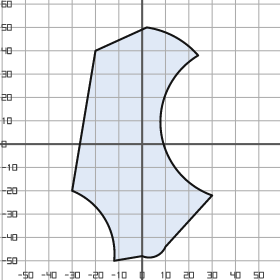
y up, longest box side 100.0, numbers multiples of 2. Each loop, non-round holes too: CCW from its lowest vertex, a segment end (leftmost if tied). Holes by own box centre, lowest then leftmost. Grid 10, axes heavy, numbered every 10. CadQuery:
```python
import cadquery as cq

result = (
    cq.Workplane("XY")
    .moveTo(-12.0, -50.0)
    .lineTo(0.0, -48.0)
    .threePointArc((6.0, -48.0), (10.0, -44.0))
    .lineTo(30.0, -22.0)
    .threePointArc((8.0, 6.0), (24.0, 38.0))
    .threePointArc((14.0, 46.0), (2.0, 50.0))
    .lineTo(-20.0, 40.0)
    .lineTo(-30.0, -20.0)
    .threePointArc((-16.0, -32.0), (-12.0, -50.0))
    .close()
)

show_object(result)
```